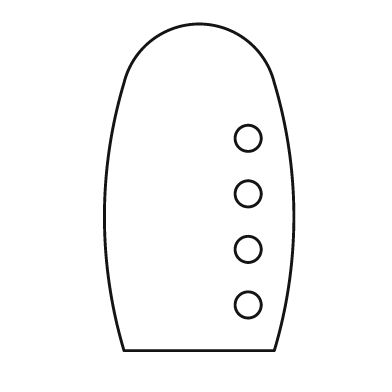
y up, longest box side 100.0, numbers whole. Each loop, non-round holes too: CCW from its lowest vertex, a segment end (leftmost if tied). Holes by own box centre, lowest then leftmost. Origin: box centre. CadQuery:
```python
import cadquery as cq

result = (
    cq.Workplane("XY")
    .moveTo(-23.0, -50.0)
    .lineTo(23.0, -50.0)
    .threePointArc((29.0, -9.0), (23.0, 32.0))
    .threePointArc((0.0, 50.0), (-23.0, 32.0))
    .threePointArc((-29.0, -9.0), (-23.0, -50.0))
    .close()
    .moveTo(15.0, -36.0)
    .circle(4.0)
    .moveTo(15.0, -19.0)
    .circle(4.0)
    .moveTo(15.0, -2.0)
    .circle(4.0)
    .moveTo(15.0, 15.0)
    .circle(4.0)
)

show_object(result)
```